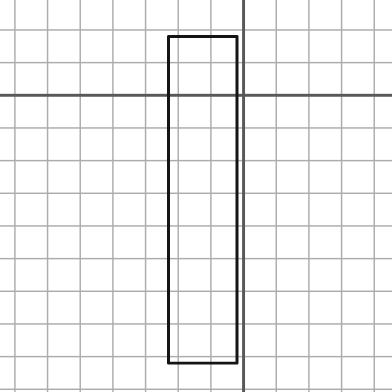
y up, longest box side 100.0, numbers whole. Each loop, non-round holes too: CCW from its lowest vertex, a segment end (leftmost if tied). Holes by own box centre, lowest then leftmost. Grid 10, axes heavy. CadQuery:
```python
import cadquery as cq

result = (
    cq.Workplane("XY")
    .moveTo(-23.0, -82.0)
    .lineTo(-2.0, -82.0)
    .lineTo(-2.0, 18.0)
    .lineTo(-23.0, 18.0)
    .close()
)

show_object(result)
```